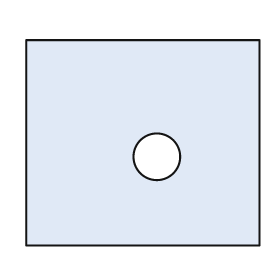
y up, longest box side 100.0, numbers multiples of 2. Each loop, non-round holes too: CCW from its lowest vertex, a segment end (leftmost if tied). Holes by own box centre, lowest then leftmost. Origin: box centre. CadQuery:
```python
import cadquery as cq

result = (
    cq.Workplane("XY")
    .moveTo(-50.0, -44.0)
    .lineTo(50.0, -44.0)
    .lineTo(50.0, 44.0)
    .lineTo(-50.0, 44.0)
    .close()
    .moveTo(6.0, -6.0)
    .circle(10.0)
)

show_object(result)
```